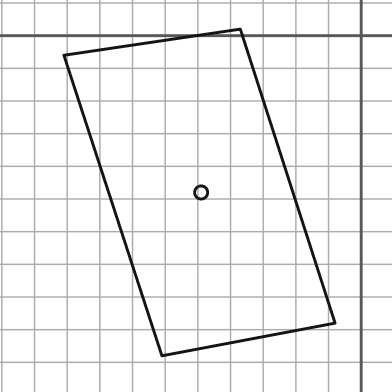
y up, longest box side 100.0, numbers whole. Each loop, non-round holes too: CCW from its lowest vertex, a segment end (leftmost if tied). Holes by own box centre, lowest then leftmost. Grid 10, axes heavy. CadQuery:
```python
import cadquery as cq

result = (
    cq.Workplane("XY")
    .moveTo(-61.0, -98.0)
    .lineTo(-8.0, -88.0)
    .lineTo(-37.0, 2.0)
    .lineTo(-91.0, -6.0)
    .close()
    .moveTo(-49.0, -48.0)
    .circle(2.0)
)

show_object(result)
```